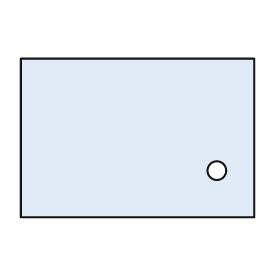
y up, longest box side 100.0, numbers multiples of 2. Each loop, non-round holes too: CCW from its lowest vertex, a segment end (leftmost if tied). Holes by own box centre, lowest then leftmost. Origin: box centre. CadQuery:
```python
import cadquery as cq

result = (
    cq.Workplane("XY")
    .moveTo(-50.0, -34.0)
    .lineTo(50.0, -34.0)
    .lineTo(50.0, 34.0)
    .lineTo(-50.0, 34.0)
    .close()
    .moveTo(34.0, -14.0)
    .circle(4.0)
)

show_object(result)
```